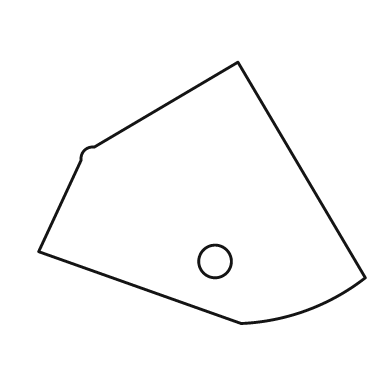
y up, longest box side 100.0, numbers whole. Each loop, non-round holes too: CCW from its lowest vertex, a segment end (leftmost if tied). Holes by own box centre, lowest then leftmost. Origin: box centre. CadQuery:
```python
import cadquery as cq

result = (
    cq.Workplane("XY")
    .moveTo(12.0, -40.0)
    .threePointArc((32.0, -36.0), (50.0, -26.0))
    .lineTo(11.0, 40.0)
    .lineTo(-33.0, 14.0)
    .threePointArc((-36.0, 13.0), (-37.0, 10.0))
    .lineTo(-50.0, -18.0)
    .close()
    .moveTo(4.0, -21.0)
    .circle(5.0)
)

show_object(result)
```